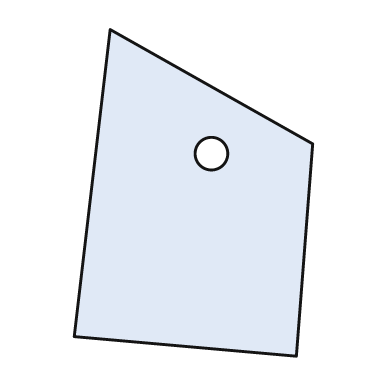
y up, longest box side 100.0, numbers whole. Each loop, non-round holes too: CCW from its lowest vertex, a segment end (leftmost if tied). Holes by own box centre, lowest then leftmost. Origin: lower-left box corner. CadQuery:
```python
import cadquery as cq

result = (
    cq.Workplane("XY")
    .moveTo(68.0, 0.0)
    .lineTo(73.0, 65.0)
    .lineTo(11.0, 100.0)
    .lineTo(0.0, 6.0)
    .close()
    .moveTo(42.0, 62.0)
    .circle(5.0)
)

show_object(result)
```